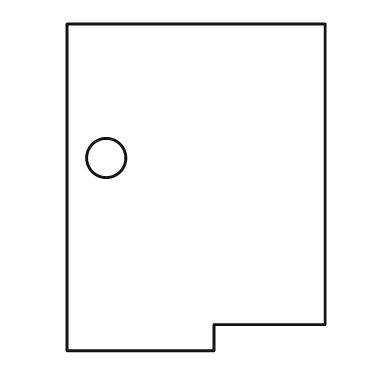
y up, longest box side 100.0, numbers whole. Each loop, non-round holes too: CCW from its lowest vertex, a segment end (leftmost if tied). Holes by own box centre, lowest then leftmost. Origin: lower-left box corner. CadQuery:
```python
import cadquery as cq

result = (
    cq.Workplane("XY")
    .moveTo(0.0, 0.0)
    .lineTo(45.0, 0.0)
    .lineTo(45.0, 8.0)
    .lineTo(79.0, 8.0)
    .lineTo(79.0, 100.0)
    .lineTo(0.0, 100.0)
    .close()
    .moveTo(12.0, 59.0)
    .circle(6.0)
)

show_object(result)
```